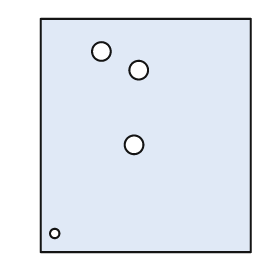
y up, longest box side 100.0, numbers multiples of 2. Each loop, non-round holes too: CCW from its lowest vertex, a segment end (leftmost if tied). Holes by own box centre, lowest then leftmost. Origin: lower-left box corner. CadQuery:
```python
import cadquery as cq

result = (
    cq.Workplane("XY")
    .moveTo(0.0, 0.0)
    .lineTo(90.0, 0.0)
    .lineTo(90.0, 100.0)
    .lineTo(0.0, 100.0)
    .close()
    .moveTo(6.0, 8.0)
    .circle(2.0)
    .moveTo(40.0, 46.0)
    .circle(4.0)
    .moveTo(42.0, 78.0)
    .circle(4.0)
    .moveTo(26.0, 86.0)
    .circle(4.0)
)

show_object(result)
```